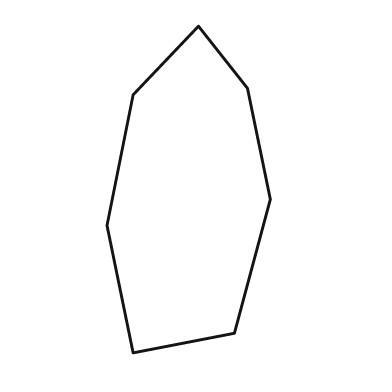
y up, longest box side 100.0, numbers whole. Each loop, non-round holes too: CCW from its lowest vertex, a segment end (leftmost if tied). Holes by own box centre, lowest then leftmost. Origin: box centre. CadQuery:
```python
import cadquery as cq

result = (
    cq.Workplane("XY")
    .moveTo(-17.0, -50.0)
    .lineTo(14.0, -44.0)
    .lineTo(25.0, -3.0)
    .lineTo(18.0, 31.0)
    .lineTo(3.0, 50.0)
    .lineTo(-17.0, 29.0)
    .lineTo(-25.0, -11.0)
    .close()
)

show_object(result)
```